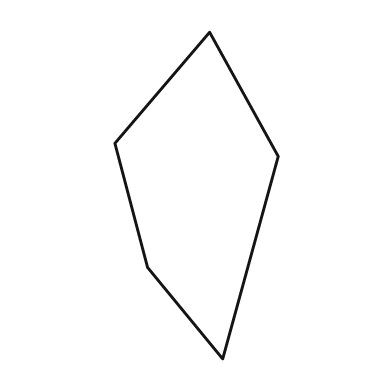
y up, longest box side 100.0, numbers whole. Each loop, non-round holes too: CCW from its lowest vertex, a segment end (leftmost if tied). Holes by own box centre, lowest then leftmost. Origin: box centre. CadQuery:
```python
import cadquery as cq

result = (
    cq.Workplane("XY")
    .moveTo(8.0, -50.0)
    .lineTo(25.0, 12.0)
    .lineTo(4.0, 50.0)
    .lineTo(-25.0, 16.0)
    .lineTo(-15.0, -22.0)
    .close()
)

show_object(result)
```